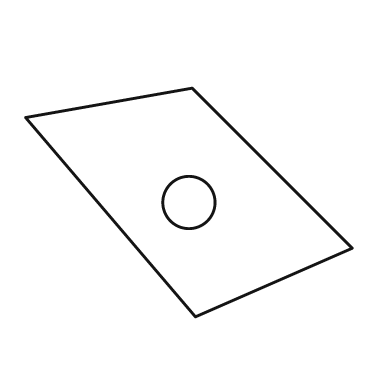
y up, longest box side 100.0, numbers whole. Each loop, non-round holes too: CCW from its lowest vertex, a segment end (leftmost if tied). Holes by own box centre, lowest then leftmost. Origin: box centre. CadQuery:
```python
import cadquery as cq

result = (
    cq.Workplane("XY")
    .moveTo(2.0, -35.0)
    .lineTo(50.0, -14.0)
    .lineTo(1.0, 35.0)
    .lineTo(-50.0, 26.0)
    .close()
    .moveTo(0.0, 0.0)
    .circle(8.0)
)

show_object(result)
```